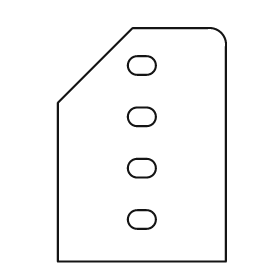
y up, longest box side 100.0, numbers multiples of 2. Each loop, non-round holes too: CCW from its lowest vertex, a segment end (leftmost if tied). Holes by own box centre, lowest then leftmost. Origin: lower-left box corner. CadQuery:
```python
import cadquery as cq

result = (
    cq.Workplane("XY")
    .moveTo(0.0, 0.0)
    .lineTo(72.0, 0.0)
    .lineTo(72.0, 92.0)
    .threePointArc((70.0, 98.0), (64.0, 100.0))
    .lineTo(32.0, 100.0)
    .lineTo(0.0, 68.0)
    .close()
    .moveTo(34.0, 14.0)
    .lineTo(38.0, 14.0)
    .threePointArc((42.0, 18.0), (38.0, 22.0))
    .lineTo(34.0, 22.0)
    .threePointArc((30.0, 18.0), (34.0, 14.0))
    .close()
    .moveTo(34.0, 36.0)
    .lineTo(38.0, 36.0)
    .threePointArc((42.0, 40.0), (38.0, 44.0))
    .lineTo(34.0, 44.0)
    .threePointArc((30.0, 40.0), (34.0, 36.0))
    .close()
    .moveTo(34.0, 58.0)
    .lineTo(38.0, 58.0)
    .threePointArc((42.0, 62.0), (38.0, 66.0))
    .lineTo(34.0, 66.0)
    .threePointArc((30.0, 62.0), (34.0, 58.0))
    .close()
    .moveTo(34.0, 80.0)
    .lineTo(38.0, 80.0)
    .threePointArc((42.0, 84.0), (38.0, 88.0))
    .lineTo(34.0, 88.0)
    .threePointArc((30.0, 84.0), (34.0, 80.0))
    .close()
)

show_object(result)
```